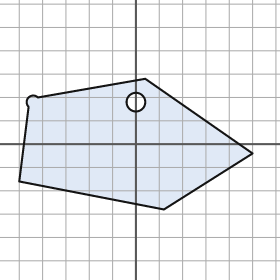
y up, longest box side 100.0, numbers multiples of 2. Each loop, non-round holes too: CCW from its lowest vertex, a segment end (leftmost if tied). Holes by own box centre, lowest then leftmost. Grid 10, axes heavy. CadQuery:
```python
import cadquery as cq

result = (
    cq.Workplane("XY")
    .moveTo(12.0, -28.0)
    .lineTo(50.0, -4.0)
    .lineTo(4.0, 28.0)
    .lineTo(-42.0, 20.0)
    .threePointArc((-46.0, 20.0), (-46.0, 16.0))
    .lineTo(-50.0, -16.0)
    .close()
    .moveTo(0.0, 18.0)
    .circle(4.0)
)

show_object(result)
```